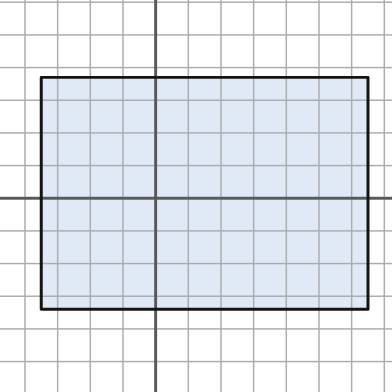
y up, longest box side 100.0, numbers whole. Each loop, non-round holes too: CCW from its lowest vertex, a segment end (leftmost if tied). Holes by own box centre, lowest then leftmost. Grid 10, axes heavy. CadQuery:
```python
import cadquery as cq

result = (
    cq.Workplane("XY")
    .moveTo(-35.0, -34.0)
    .lineTo(65.0, -34.0)
    .lineTo(65.0, 37.0)
    .lineTo(-35.0, 37.0)
    .close()
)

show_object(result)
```